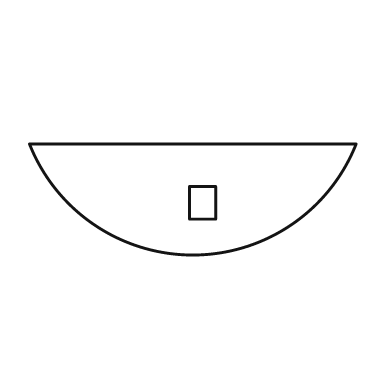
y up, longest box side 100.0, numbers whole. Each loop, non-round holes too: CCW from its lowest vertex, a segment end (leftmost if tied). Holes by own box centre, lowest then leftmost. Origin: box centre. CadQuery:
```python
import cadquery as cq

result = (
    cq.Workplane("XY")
    .moveTo(-50.0, 17.0)
    .threePointArc((0.0, -17.0), (50.0, 17.0))
    .close()
    .moveTo(-1.0, -6.0)
    .lineTo(7.0, -6.0)
    .lineTo(7.0, 4.0)
    .lineTo(-1.0, 4.0)
    .close()
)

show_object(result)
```